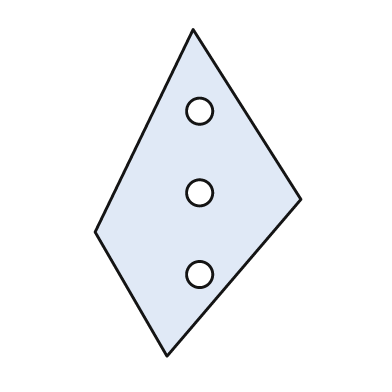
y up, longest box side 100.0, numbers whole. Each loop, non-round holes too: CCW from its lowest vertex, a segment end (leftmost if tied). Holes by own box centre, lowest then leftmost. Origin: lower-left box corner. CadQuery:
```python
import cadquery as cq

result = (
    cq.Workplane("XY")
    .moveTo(22.0, 0.0)
    .lineTo(63.0, 48.0)
    .lineTo(30.0, 100.0)
    .lineTo(0.0, 38.0)
    .close()
    .moveTo(32.0, 25.0)
    .circle(4.0)
    .moveTo(32.0, 50.0)
    .circle(4.0)
    .moveTo(32.0, 75.0)
    .circle(4.0)
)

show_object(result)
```